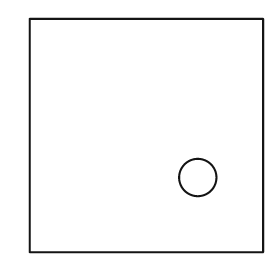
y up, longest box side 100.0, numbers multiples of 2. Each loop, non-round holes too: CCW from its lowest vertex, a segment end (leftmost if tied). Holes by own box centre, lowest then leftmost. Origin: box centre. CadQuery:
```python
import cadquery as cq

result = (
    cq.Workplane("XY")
    .moveTo(-50.0, -50.0)
    .lineTo(50.0, -50.0)
    .lineTo(50.0, 50.0)
    .lineTo(-50.0, 50.0)
    .close()
    .moveTo(22.0, -18.0)
    .circle(8.0)
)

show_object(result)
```